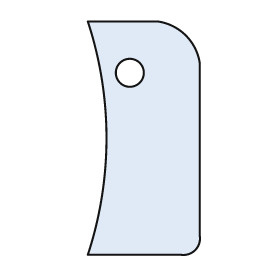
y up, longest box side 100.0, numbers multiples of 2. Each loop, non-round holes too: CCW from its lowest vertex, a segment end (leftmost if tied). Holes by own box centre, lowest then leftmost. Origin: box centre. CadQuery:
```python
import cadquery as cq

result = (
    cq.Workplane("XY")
    .moveTo(-24.0, -50.0)
    .lineTo(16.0, -50.0)
    .threePointArc((22.0, -48.0), (24.0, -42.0))
    .lineTo(24.0, 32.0)
    .threePointArc((18.0, 44.0), (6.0, 50.0))
    .lineTo(-24.0, 50.0)
    .threePointArc((-16.0, 0.0), (-24.0, -50.0))
    .close()
    .moveTo(-6.0, 28.0)
    .circle(6.0)
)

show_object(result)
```